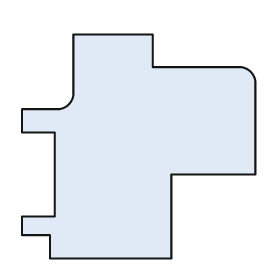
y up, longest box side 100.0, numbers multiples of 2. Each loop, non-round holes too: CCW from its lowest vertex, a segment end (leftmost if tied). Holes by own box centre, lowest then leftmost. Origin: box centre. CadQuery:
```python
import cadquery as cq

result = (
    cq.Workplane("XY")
    .moveTo(-38.0, -48.0)
    .lineTo(14.0, -48.0)
    .lineTo(14.0, -12.0)
    .lineTo(50.0, -12.0)
    .lineTo(50.0, 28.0)
    .threePointArc((48.0, 32.0), (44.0, 34.0))
    .lineTo(6.0, 34.0)
    .lineTo(6.0, 48.0)
    .lineTo(-28.0, 48.0)
    .lineTo(-28.0, 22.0)
    .threePointArc((-30.0, 18.0), (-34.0, 16.0))
    .lineTo(-50.0, 16.0)
    .lineTo(-50.0, 6.0)
    .lineTo(-36.0, 6.0)
    .lineTo(-36.0, -30.0)
    .lineTo(-50.0, -30.0)
    .lineTo(-50.0, -38.0)
    .lineTo(-38.0, -38.0)
    .close()
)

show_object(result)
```